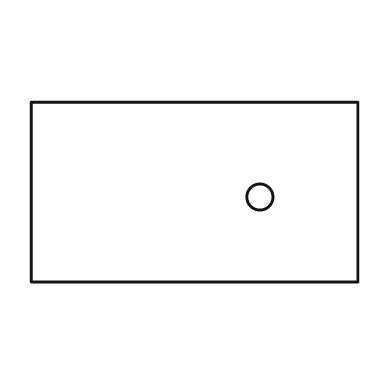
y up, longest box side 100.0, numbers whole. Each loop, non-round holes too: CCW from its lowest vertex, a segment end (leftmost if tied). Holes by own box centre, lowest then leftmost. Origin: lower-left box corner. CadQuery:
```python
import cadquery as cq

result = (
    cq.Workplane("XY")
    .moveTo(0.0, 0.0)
    .lineTo(100.0, 0.0)
    .lineTo(100.0, 55.0)
    .lineTo(0.0, 55.0)
    .close()
    .moveTo(70.0, 26.0)
    .circle(4.0)
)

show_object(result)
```